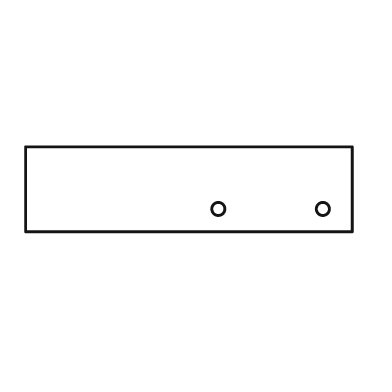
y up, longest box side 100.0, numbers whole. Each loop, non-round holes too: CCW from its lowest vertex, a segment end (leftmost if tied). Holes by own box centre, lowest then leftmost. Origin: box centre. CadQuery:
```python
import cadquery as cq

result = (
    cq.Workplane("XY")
    .moveTo(-50.0, -13.0)
    .lineTo(50.0, -13.0)
    .lineTo(50.0, 13.0)
    .lineTo(-50.0, 13.0)
    .close()
    .moveTo(9.0, -6.0)
    .circle(2.0)
    .moveTo(41.0, -6.0)
    .circle(2.0)
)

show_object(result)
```